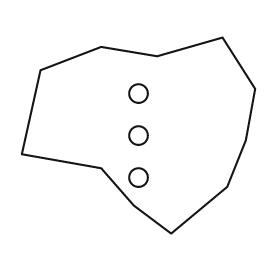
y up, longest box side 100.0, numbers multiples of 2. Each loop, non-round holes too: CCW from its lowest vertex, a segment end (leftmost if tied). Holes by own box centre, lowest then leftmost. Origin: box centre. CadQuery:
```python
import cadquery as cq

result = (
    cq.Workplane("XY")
    .moveTo(14.0, -42.0)
    .lineTo(38.0, -22.0)
    .lineTo(46.0, -2.0)
    .lineTo(50.0, 20.0)
    .lineTo(36.0, 42.0)
    .lineTo(8.0, 34.0)
    .lineTo(-16.0, 38.0)
    .lineTo(-42.0, 28.0)
    .lineTo(-50.0, -8.0)
    .lineTo(-16.0, -14.0)
    .lineTo(-2.0, -30.0)
    .close()
    .moveTo(0.0, -18.0)
    .circle(4.0)
    .moveTo(0.0, 0.0)
    .circle(4.0)
    .moveTo(0.0, 18.0)
    .circle(4.0)
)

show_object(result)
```